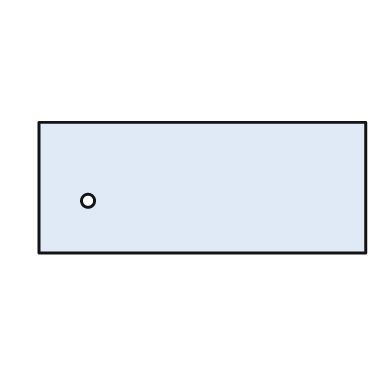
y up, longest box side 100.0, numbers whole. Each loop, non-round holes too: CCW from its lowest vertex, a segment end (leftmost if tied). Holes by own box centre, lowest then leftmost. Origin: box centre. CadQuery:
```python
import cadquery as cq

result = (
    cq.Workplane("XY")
    .moveTo(-50.0, -20.0)
    .lineTo(50.0, -20.0)
    .lineTo(50.0, 20.0)
    .lineTo(-50.0, 20.0)
    .close()
    .moveTo(-35.0, -4.0)
    .circle(2.0)
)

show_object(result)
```